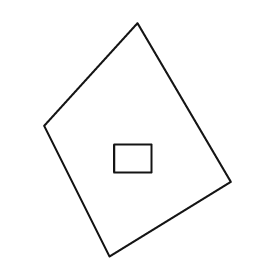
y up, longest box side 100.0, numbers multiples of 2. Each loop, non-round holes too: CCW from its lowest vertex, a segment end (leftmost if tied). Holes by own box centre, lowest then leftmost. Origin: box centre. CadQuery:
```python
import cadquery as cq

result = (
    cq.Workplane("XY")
    .moveTo(-12.0, -50.0)
    .lineTo(40.0, -18.0)
    .lineTo(0.0, 50.0)
    .lineTo(-40.0, 6.0)
    .close()
    .moveTo(-10.0, -14.0)
    .lineTo(6.0, -14.0)
    .lineTo(6.0, -2.0)
    .lineTo(-10.0, -2.0)
    .close()
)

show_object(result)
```